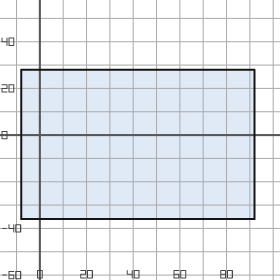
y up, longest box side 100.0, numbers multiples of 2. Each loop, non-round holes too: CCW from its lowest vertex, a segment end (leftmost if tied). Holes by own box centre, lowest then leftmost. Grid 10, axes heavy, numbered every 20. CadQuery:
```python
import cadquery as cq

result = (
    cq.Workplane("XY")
    .moveTo(-8.0, -36.0)
    .lineTo(92.0, -36.0)
    .lineTo(92.0, 28.0)
    .lineTo(-8.0, 28.0)
    .close()
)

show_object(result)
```